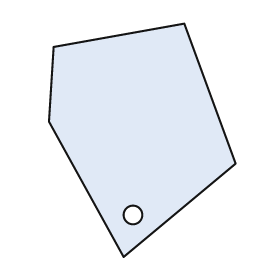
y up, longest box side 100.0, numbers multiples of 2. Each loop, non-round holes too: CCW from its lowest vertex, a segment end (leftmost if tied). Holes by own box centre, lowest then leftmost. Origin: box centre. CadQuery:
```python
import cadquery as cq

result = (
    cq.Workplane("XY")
    .moveTo(-8.0, -50.0)
    .lineTo(40.0, -10.0)
    .lineTo(18.0, 50.0)
    .lineTo(-38.0, 40.0)
    .lineTo(-40.0, 8.0)
    .close()
    .moveTo(-4.0, -32.0)
    .circle(4.0)
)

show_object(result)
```